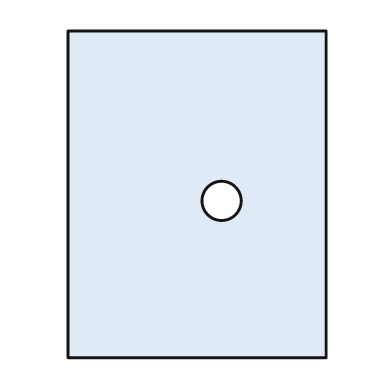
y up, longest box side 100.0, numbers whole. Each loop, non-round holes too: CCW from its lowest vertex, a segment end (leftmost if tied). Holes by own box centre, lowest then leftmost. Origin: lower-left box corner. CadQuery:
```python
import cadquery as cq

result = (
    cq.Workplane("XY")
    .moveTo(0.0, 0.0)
    .lineTo(79.0, 0.0)
    .lineTo(79.0, 100.0)
    .lineTo(0.0, 100.0)
    .close()
    .moveTo(47.0, 48.0)
    .circle(6.0)
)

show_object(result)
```